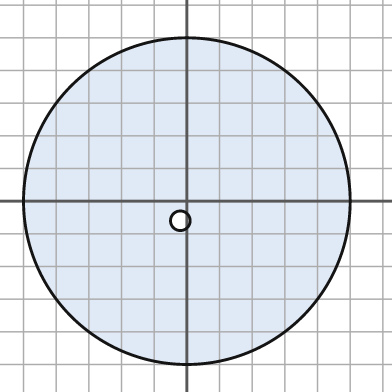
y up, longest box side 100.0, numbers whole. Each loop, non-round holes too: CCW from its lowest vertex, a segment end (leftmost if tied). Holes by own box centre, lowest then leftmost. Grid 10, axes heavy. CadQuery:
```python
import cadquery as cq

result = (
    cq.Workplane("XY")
    .moveTo(0.0, 0.0)
    .circle(50.0)
    .moveTo(-2.0, -6.0)
    .circle(3.0)
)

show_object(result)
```